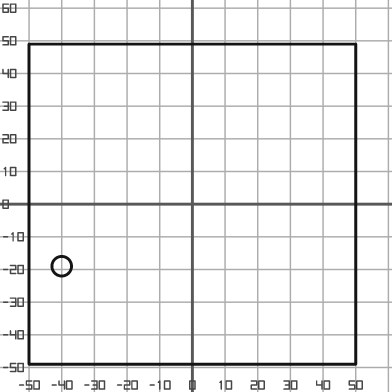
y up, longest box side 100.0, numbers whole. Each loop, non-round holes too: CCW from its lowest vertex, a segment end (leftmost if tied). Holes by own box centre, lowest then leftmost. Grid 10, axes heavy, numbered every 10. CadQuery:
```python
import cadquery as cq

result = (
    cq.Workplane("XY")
    .moveTo(-50.0, -49.0)
    .lineTo(50.0, -49.0)
    .lineTo(50.0, 49.0)
    .lineTo(-50.0, 49.0)
    .close()
    .moveTo(-40.0, -19.0)
    .circle(3.0)
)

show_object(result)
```